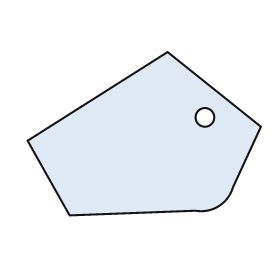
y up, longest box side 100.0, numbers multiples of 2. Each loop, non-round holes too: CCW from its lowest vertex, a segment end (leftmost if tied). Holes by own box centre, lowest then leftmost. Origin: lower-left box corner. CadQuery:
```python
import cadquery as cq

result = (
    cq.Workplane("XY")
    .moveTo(18.0, 0.0)
    .lineTo(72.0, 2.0)
    .threePointArc((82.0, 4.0), (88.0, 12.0))
    .lineTo(100.0, 38.0)
    .lineTo(60.0, 70.0)
    .lineTo(0.0, 32.0)
    .close()
    .moveTo(76.0, 42.0)
    .circle(4.0)
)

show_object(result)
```